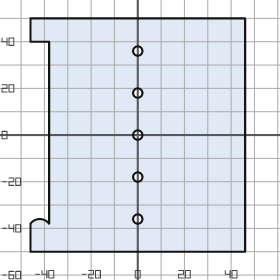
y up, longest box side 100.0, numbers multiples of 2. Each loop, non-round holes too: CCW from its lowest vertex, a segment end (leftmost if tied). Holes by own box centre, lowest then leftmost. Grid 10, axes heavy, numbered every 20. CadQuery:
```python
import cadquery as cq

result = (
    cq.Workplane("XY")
    .moveTo(-46.0, -50.0)
    .lineTo(46.0, -50.0)
    .lineTo(46.0, 50.0)
    .lineTo(-46.0, 50.0)
    .lineTo(-46.0, 40.0)
    .lineTo(-38.0, 40.0)
    .lineTo(-38.0, -38.0)
    .threePointArc((-42.0, -36.0), (-46.0, -38.0))
    .close()
    .moveTo(0.0, -36.0)
    .circle(2.0)
    .moveTo(0.0, -18.0)
    .circle(2.0)
    .moveTo(0.0, 0.0)
    .circle(2.0)
    .moveTo(0.0, 18.0)
    .circle(2.0)
    .moveTo(0.0, 36.0)
    .circle(2.0)
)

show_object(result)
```